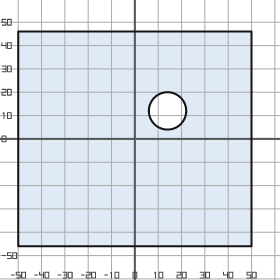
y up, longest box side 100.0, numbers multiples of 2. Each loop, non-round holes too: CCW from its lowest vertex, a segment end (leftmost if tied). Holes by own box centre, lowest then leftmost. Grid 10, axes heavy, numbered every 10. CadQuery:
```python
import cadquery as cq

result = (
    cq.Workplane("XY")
    .moveTo(-50.0, -46.0)
    .lineTo(50.0, -46.0)
    .lineTo(50.0, 46.0)
    .lineTo(-50.0, 46.0)
    .close()
    .moveTo(14.0, 12.0)
    .circle(8.0)
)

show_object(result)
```